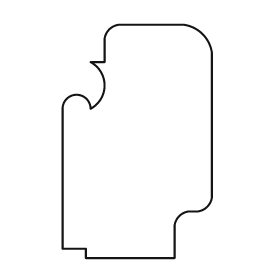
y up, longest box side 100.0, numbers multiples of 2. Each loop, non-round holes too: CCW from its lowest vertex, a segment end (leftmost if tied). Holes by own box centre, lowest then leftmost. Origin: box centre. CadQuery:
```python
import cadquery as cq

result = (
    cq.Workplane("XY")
    .moveTo(-22.0, -50.0)
    .lineTo(16.0, -50.0)
    .lineTo(16.0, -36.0)
    .threePointArc((18.0, -32.0), (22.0, -30.0))
    .lineTo(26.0, -30.0)
    .threePointArc((30.0, -28.0), (32.0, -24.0))
    .lineTo(32.0, 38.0)
    .threePointArc((28.0, 46.0), (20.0, 50.0))
    .lineTo(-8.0, 50.0)
    .threePointArc((-12.0, 48.0), (-14.0, 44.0))
    .lineTo(-14.0, 34.0)
    .lineTo(-20.0, 34.0)
    .threePointArc((-14.0, 24.0), (-20.0, 14.0))
    .threePointArc((-26.0, 20.0), (-32.0, 14.0))
    .lineTo(-32.0, -46.0)
    .lineTo(-22.0, -46.0)
    .close()
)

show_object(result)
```